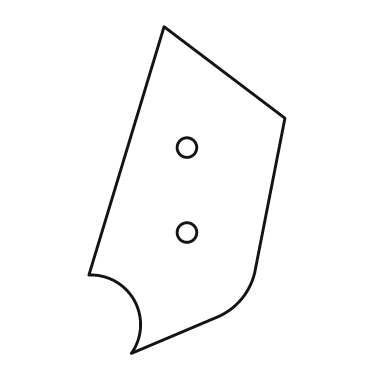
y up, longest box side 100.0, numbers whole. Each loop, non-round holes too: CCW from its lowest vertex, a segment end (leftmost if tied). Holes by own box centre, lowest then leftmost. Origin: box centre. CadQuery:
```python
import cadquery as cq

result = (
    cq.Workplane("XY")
    .moveTo(-17.0, -50.0)
    .lineTo(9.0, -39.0)
    .threePointArc((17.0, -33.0), (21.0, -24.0))
    .lineTo(30.0, 22.0)
    .lineTo(-7.0, 50.0)
    .lineTo(-30.0, -26.0)
    .threePointArc((-16.0, -34.0), (-17.0, -50.0))
    .close()
    .moveTo(0.0, -13.0)
    .circle(3.0)
    .moveTo(0.0, 13.0)
    .circle(3.0)
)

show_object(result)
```